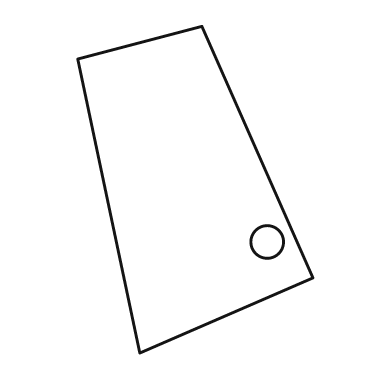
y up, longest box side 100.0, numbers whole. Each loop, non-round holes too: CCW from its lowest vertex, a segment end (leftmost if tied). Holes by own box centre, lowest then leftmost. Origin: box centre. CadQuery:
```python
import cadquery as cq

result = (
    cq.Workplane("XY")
    .moveTo(-17.0, -50.0)
    .lineTo(36.0, -27.0)
    .lineTo(2.0, 50.0)
    .lineTo(-36.0, 40.0)
    .close()
    .moveTo(22.0, -16.0)
    .circle(5.0)
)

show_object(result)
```